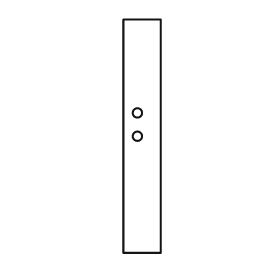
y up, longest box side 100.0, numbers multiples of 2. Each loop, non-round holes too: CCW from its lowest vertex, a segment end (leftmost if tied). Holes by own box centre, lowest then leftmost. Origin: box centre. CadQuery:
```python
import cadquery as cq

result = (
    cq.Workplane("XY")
    .moveTo(-8.0, -50.0)
    .lineTo(8.0, -50.0)
    .lineTo(8.0, 50.0)
    .lineTo(-8.0, 50.0)
    .close()
    .moveTo(-2.0, 0.0)
    .circle(2.0)
    .moveTo(-2.0, 10.0)
    .circle(2.0)
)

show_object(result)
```